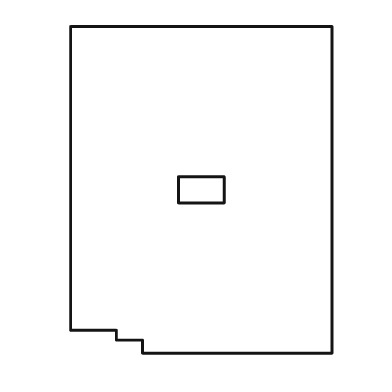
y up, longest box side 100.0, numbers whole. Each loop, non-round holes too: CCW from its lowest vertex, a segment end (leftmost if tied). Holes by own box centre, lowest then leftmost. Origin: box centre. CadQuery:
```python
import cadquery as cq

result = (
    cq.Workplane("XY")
    .moveTo(-18.0, -50.0)
    .lineTo(40.0, -50.0)
    .lineTo(40.0, 50.0)
    .lineTo(-40.0, 50.0)
    .lineTo(-40.0, -43.0)
    .lineTo(-26.0, -43.0)
    .lineTo(-26.0, -46.0)
    .lineTo(-18.0, -46.0)
    .close()
    .moveTo(-7.0, -4.0)
    .lineTo(7.0, -4.0)
    .lineTo(7.0, 4.0)
    .lineTo(-7.0, 4.0)
    .close()
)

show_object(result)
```